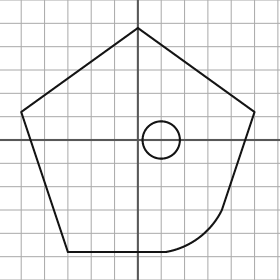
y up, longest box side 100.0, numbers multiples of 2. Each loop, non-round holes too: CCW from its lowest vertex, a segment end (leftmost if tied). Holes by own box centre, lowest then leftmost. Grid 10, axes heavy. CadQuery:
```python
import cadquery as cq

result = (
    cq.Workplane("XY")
    .moveTo(-30.0, -48.0)
    .lineTo(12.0, -48.0)
    .threePointArc((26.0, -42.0), (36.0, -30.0))
    .lineTo(50.0, 12.0)
    .lineTo(0.0, 48.0)
    .lineTo(-50.0, 12.0)
    .close()
    .moveTo(10.0, 0.0)
    .circle(8.0)
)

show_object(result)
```